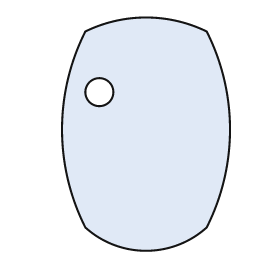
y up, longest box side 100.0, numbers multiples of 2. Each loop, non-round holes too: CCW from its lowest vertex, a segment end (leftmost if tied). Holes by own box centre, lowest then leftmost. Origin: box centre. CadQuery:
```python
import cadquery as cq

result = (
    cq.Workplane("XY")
    .moveTo(-26.0, -40.0)
    .threePointArc((0.0, -50.0), (26.0, -40.0))
    .threePointArc((36.0, 2.0), (26.0, 44.0))
    .threePointArc((0.0, 50.0), (-26.0, 44.0))
    .threePointArc((-36.0, 2.0), (-26.0, -40.0))
    .close()
    .moveTo(-20.0, 18.0)
    .circle(6.0)
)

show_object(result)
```